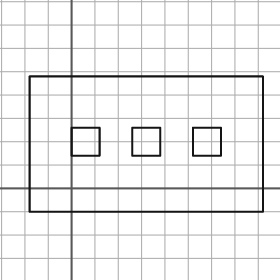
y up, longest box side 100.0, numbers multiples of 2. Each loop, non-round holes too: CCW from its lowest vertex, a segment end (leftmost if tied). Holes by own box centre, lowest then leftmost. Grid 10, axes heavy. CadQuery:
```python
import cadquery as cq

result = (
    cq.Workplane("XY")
    .moveTo(-18.0, -10.0)
    .lineTo(82.0, -10.0)
    .lineTo(82.0, 48.0)
    .lineTo(-18.0, 48.0)
    .close()
    .moveTo(0.0, 14.0)
    .lineTo(12.0, 14.0)
    .lineTo(12.0, 26.0)
    .lineTo(0.0, 26.0)
    .close()
    .moveTo(26.0, 14.0)
    .lineTo(38.0, 14.0)
    .lineTo(38.0, 26.0)
    .lineTo(26.0, 26.0)
    .close()
    .moveTo(52.0, 14.0)
    .lineTo(64.0, 14.0)
    .lineTo(64.0, 26.0)
    .lineTo(52.0, 26.0)
    .close()
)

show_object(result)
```